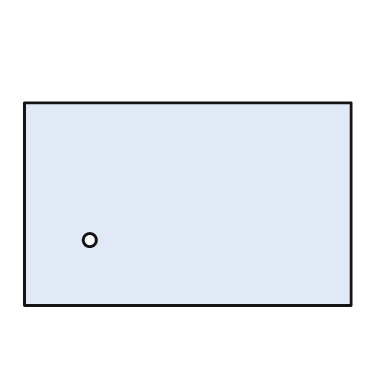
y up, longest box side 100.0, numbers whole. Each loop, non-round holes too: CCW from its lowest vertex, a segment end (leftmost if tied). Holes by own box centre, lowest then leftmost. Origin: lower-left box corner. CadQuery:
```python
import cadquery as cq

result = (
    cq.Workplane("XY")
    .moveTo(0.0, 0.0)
    .lineTo(100.0, 0.0)
    .lineTo(100.0, 62.0)
    .lineTo(0.0, 62.0)
    .close()
    .moveTo(20.0, 20.0)
    .circle(2.0)
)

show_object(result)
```